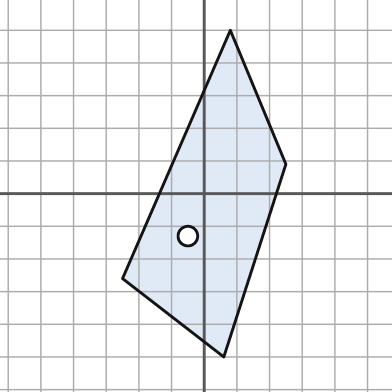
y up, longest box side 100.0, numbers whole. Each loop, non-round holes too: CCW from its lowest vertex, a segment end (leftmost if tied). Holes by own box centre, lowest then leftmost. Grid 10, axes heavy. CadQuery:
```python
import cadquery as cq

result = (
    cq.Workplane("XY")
    .moveTo(6.0, -50.0)
    .lineTo(25.0, 9.0)
    .lineTo(8.0, 50.0)
    .lineTo(-25.0, -26.0)
    .close()
    .moveTo(-5.0, -13.0)
    .circle(3.0)
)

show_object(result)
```